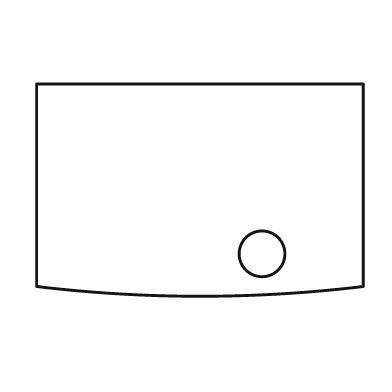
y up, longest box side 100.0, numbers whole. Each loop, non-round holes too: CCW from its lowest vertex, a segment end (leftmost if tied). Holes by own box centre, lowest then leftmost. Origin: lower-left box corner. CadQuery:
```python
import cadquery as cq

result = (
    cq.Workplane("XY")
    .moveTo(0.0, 3.0)
    .threePointArc((50.0, 0.0), (100.0, 3.0))
    .lineTo(100.0, 65.0)
    .lineTo(0.0, 65.0)
    .close()
    .moveTo(69.0, 13.0)
    .circle(7.0)
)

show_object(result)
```